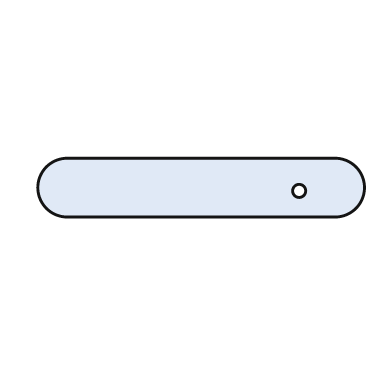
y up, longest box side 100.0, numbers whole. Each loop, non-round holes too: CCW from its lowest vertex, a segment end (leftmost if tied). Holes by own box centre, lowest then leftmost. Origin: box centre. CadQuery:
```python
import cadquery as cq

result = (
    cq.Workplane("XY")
    .moveTo(-41.0, -9.0)
    .lineTo(41.0, -9.0)
    .threePointArc((50.0, 0.0), (41.0, 9.0))
    .lineTo(-41.0, 9.0)
    .threePointArc((-50.0, 0.0), (-41.0, -9.0))
    .close()
    .moveTo(30.0, -1.0)
    .circle(2.0)
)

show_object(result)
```